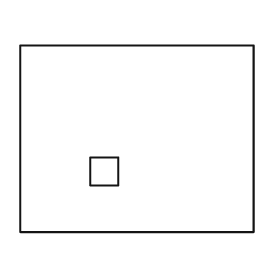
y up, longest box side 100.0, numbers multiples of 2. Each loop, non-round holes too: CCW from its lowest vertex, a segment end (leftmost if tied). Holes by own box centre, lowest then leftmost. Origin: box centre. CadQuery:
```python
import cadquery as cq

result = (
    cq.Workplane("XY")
    .moveTo(-50.0, -40.0)
    .lineTo(50.0, -40.0)
    .lineTo(50.0, 40.0)
    .lineTo(-50.0, 40.0)
    .close()
    .moveTo(-20.0, -20.0)
    .lineTo(-8.0, -20.0)
    .lineTo(-8.0, -8.0)
    .lineTo(-20.0, -8.0)
    .close()
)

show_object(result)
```